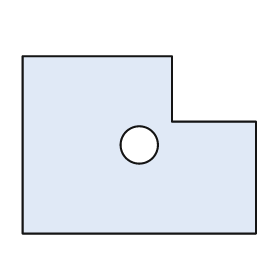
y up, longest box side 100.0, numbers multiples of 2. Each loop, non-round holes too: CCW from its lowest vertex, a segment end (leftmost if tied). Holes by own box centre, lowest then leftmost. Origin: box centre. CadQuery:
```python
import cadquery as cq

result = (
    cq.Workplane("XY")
    .moveTo(-50.0, -38.0)
    .lineTo(50.0, -38.0)
    .lineTo(50.0, 10.0)
    .lineTo(14.0, 10.0)
    .lineTo(14.0, 38.0)
    .lineTo(-50.0, 38.0)
    .close()
    .moveTo(0.0, 0.0)
    .circle(8.0)
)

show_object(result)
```